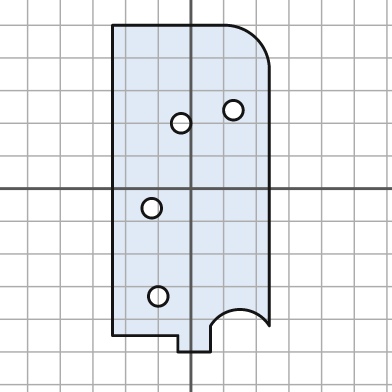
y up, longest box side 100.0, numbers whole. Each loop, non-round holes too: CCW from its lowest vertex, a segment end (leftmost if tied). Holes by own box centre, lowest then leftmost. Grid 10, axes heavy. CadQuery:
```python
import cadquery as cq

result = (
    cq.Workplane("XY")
    .moveTo(-4.0, -50.0)
    .lineTo(6.0, -50.0)
    .lineTo(6.0, -42.0)
    .threePointArc((15.0, -37.0), (24.0, -42.0))
    .lineTo(24.0, 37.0)
    .threePointArc((20.0, 46.0), (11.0, 50.0))
    .lineTo(-24.0, 50.0)
    .lineTo(-24.0, -45.0)
    .lineTo(-4.0, -45.0)
    .close()
    .moveTo(-10.0, -33.0)
    .circle(3.0)
    .moveTo(-12.0, -6.0)
    .circle(3.0)
    .moveTo(-3.0, 20.0)
    .circle(3.0)
    .moveTo(13.0, 24.0)
    .circle(3.0)
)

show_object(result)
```